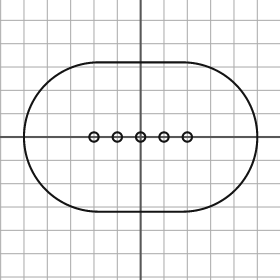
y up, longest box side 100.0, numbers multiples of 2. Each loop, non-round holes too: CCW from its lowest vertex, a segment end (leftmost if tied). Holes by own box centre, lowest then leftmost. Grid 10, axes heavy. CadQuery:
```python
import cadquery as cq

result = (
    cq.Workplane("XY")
    .moveTo(-18.0, -32.0)
    .lineTo(18.0, -32.0)
    .threePointArc((50.0, 0.0), (18.0, 32.0))
    .lineTo(-18.0, 32.0)
    .threePointArc((-50.0, 0.0), (-18.0, -32.0))
    .close()
    .moveTo(-20.0, 0.0)
    .circle(2.0)
    .moveTo(-10.0, 0.0)
    .circle(2.0)
    .moveTo(0.0, 0.0)
    .circle(2.0)
    .moveTo(10.0, 0.0)
    .circle(2.0)
    .moveTo(20.0, 0.0)
    .circle(2.0)
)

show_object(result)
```